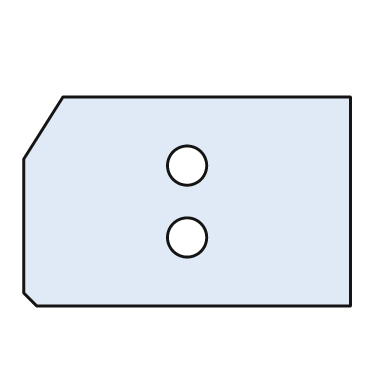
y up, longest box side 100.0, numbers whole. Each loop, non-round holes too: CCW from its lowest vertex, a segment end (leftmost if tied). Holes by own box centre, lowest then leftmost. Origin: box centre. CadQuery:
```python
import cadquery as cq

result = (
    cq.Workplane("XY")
    .moveTo(-46.0, -32.0)
    .lineTo(50.0, -32.0)
    .lineTo(50.0, 32.0)
    .lineTo(-38.0, 32.0)
    .lineTo(-50.0, 13.0)
    .lineTo(-50.0, -28.0)
    .close()
    .moveTo(0.0, -11.0)
    .circle(6.0)
    .moveTo(0.0, 11.0)
    .circle(6.0)
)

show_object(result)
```